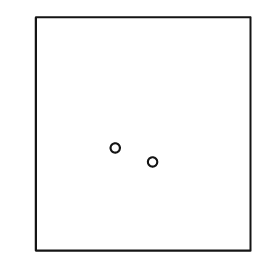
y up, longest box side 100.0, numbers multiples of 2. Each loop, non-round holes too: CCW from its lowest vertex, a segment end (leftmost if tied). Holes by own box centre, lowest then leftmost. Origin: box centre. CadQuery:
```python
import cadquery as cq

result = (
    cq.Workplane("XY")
    .moveTo(-46.0, -50.0)
    .lineTo(46.0, -50.0)
    .lineTo(46.0, 50.0)
    .lineTo(-46.0, 50.0)
    .close()
    .moveTo(4.0, -12.0)
    .circle(2.0)
    .moveTo(-12.0, -6.0)
    .circle(2.0)
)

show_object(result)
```